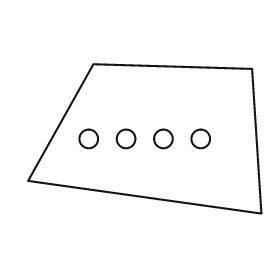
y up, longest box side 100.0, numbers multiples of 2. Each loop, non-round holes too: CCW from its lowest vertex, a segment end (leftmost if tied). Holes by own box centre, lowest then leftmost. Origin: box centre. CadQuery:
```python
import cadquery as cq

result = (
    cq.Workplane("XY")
    .moveTo(50.0, -32.0)
    .lineTo(46.0, 30.0)
    .lineTo(-22.0, 32.0)
    .lineTo(-50.0, -18.0)
    .close()
    .moveTo(-24.0, 0.0)
    .circle(4.0)
    .moveTo(-8.0, 0.0)
    .circle(4.0)
    .moveTo(8.0, 0.0)
    .circle(4.0)
    .moveTo(24.0, 0.0)
    .circle(4.0)
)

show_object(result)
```